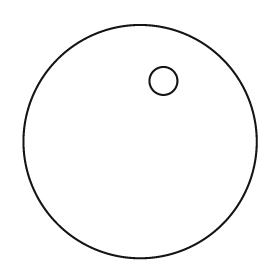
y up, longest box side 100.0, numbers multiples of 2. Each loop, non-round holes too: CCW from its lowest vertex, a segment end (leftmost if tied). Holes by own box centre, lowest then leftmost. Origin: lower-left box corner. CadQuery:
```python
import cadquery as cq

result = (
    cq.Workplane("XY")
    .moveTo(50.0, 50.0)
    .circle(50.0)
    .moveTo(60.0, 76.0)
    .circle(6.0)
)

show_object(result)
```